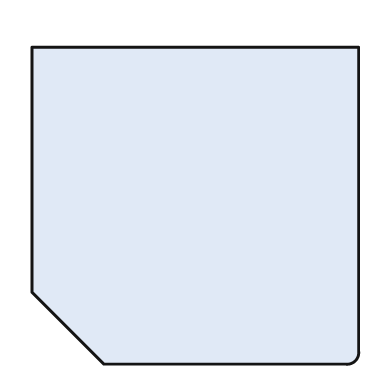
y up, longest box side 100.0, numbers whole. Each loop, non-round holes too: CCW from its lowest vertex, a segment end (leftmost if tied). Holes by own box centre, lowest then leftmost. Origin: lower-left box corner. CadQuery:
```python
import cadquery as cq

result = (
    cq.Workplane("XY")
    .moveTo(22.0, 0.0)
    .lineTo(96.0, 0.0)
    .threePointArc((99.0, 1.0), (100.0, 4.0))
    .lineTo(100.0, 97.0)
    .lineTo(0.0, 97.0)
    .lineTo(0.0, 22.0)
    .close()
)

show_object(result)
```